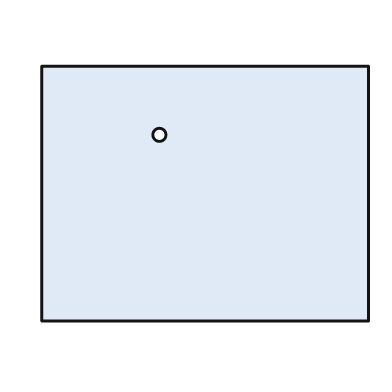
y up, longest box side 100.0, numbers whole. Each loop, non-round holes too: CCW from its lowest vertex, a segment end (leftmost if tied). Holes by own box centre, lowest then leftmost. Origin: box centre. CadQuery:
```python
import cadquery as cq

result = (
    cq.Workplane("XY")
    .moveTo(-50.0, -39.0)
    .lineTo(50.0, -39.0)
    .lineTo(50.0, 39.0)
    .lineTo(-50.0, 39.0)
    .close()
    .moveTo(-14.0, 18.0)
    .circle(2.0)
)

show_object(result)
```